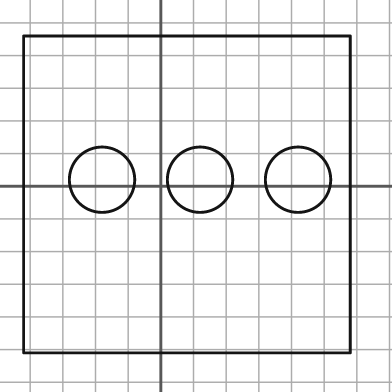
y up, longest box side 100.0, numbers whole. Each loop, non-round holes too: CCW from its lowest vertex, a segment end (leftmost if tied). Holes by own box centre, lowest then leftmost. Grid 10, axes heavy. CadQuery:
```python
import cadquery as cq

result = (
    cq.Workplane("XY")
    .moveTo(-42.0, -51.0)
    .lineTo(58.0, -51.0)
    .lineTo(58.0, 46.0)
    .lineTo(-42.0, 46.0)
    .close()
    .moveTo(-18.0, 2.0)
    .circle(10.0)
    .moveTo(12.0, 2.0)
    .circle(10.0)
    .moveTo(42.0, 2.0)
    .circle(10.0)
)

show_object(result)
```